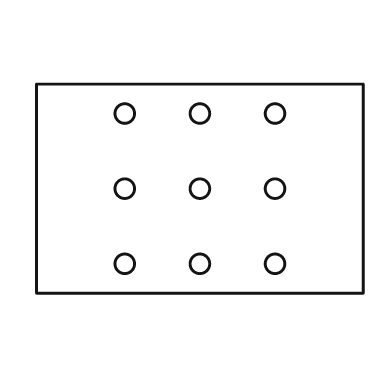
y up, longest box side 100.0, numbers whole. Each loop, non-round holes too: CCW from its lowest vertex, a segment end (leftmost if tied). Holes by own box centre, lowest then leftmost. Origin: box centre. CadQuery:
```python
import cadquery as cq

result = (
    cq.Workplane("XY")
    .moveTo(-50.0, -32.0)
    .lineTo(50.0, -32.0)
    .lineTo(50.0, 32.0)
    .lineTo(-50.0, 32.0)
    .close()
    .moveTo(-23.0, -23.0)
    .circle(3.0)
    .moveTo(0.0, -23.0)
    .circle(3.0)
    .moveTo(23.0, -23.0)
    .circle(3.0)
    .moveTo(-23.0, 0.0)
    .circle(3.0)
    .moveTo(0.0, 0.0)
    .circle(3.0)
    .moveTo(23.0, 0.0)
    .circle(3.0)
    .moveTo(-23.0, 23.0)
    .circle(3.0)
    .moveTo(0.0, 23.0)
    .circle(3.0)
    .moveTo(23.0, 23.0)
    .circle(3.0)
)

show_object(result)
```